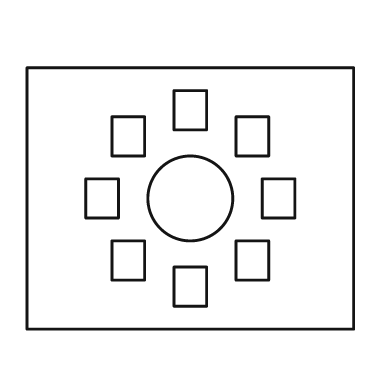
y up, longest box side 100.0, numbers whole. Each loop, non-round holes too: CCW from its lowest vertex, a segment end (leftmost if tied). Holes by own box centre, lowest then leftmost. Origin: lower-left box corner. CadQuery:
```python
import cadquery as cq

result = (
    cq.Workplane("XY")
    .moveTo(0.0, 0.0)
    .lineTo(100.0, 0.0)
    .lineTo(100.0, 80.0)
    .lineTo(0.0, 80.0)
    .close()
    .moveTo(45.0, 7.0)
    .lineTo(55.0, 7.0)
    .lineTo(55.0, 19.0)
    .lineTo(45.0, 19.0)
    .close()
    .moveTo(26.0, 15.0)
    .lineTo(36.0, 15.0)
    .lineTo(36.0, 27.0)
    .lineTo(26.0, 27.0)
    .close()
    .moveTo(64.0, 15.0)
    .lineTo(74.0, 15.0)
    .lineTo(74.0, 27.0)
    .lineTo(64.0, 27.0)
    .close()
    .moveTo(18.0, 34.0)
    .lineTo(28.0, 34.0)
    .lineTo(28.0, 46.0)
    .lineTo(18.0, 46.0)
    .close()
    .moveTo(50.0, 40.0)
    .circle(13.0)
    .moveTo(72.0, 34.0)
    .lineTo(82.0, 34.0)
    .lineTo(82.0, 46.0)
    .lineTo(72.0, 46.0)
    .close()
    .moveTo(26.0, 53.0)
    .lineTo(36.0, 53.0)
    .lineTo(36.0, 65.0)
    .lineTo(26.0, 65.0)
    .close()
    .moveTo(64.0, 53.0)
    .lineTo(74.0, 53.0)
    .lineTo(74.0, 65.0)
    .lineTo(64.0, 65.0)
    .close()
    .moveTo(45.0, 61.0)
    .lineTo(55.0, 61.0)
    .lineTo(55.0, 73.0)
    .lineTo(45.0, 73.0)
    .close()
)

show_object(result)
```